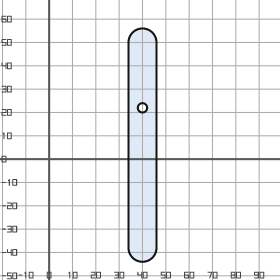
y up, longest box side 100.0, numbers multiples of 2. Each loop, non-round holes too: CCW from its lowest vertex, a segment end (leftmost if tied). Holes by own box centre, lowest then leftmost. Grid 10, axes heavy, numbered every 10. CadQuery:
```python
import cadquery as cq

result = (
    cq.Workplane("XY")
    .moveTo(34.0, -38.0)
    .threePointArc((40.0, -44.0), (46.0, -38.0))
    .lineTo(46.0, 50.0)
    .threePointArc((40.0, 56.0), (34.0, 50.0))
    .close()
    .moveTo(40.0, 22.0)
    .circle(2.0)
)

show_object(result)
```